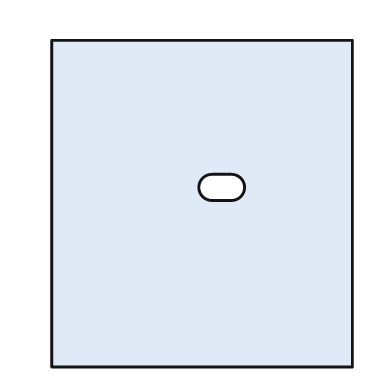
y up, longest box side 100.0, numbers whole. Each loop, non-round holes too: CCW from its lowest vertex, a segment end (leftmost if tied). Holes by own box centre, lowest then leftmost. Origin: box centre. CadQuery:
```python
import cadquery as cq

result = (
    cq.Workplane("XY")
    .moveTo(-46.0, -50.0)
    .lineTo(46.0, -50.0)
    .lineTo(46.0, 50.0)
    .lineTo(-46.0, 50.0)
    .close()
    .moveTo(3.0, 1.0)
    .lineTo(9.0, 1.0)
    .threePointArc((13.0, 5.0), (9.0, 9.0))
    .lineTo(3.0, 9.0)
    .threePointArc((-1.0, 5.0), (3.0, 1.0))
    .close()
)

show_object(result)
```